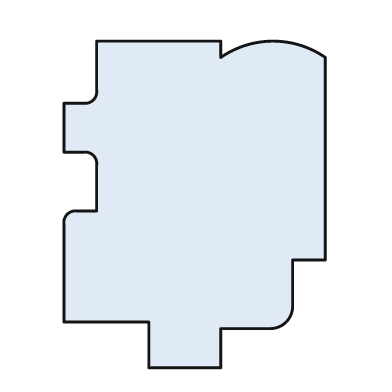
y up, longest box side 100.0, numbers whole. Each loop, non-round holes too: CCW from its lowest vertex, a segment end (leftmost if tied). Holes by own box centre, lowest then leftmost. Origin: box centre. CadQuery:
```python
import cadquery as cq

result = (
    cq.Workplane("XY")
    .moveTo(-14.0, -50.0)
    .lineTo(8.0, -50.0)
    .lineTo(8.0, -38.0)
    .lineTo(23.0, -38.0)
    .threePointArc((28.0, -36.0), (30.0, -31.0))
    .lineTo(30.0, -17.0)
    .lineTo(40.0, -17.0)
    .lineTo(40.0, 45.0)
    .threePointArc((24.0, 50.0), (8.0, 45.0))
    .lineTo(8.0, 50.0)
    .lineTo(-30.0, 50.0)
    .lineTo(-30.0, 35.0)
    .threePointArc((-31.0, 32.0), (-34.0, 31.0))
    .lineTo(-40.0, 31.0)
    .lineTo(-40.0, 16.0)
    .lineTo(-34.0, 16.0)
    .threePointArc((-31.0, 15.0), (-30.0, 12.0))
    .lineTo(-30.0, -2.0)
    .lineTo(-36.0, -2.0)
    .threePointArc((-39.0, -3.0), (-40.0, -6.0))
    .lineTo(-40.0, -36.0)
    .lineTo(-14.0, -36.0)
    .close()
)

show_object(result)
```